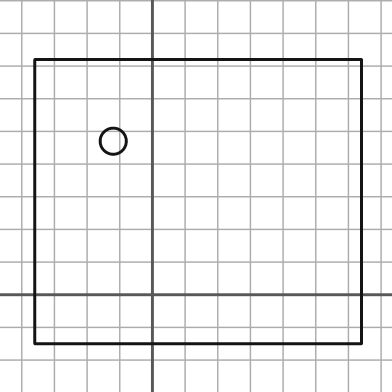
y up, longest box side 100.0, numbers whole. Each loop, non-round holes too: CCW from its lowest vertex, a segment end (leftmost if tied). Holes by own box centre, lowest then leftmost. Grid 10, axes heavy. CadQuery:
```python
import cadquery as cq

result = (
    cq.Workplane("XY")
    .moveTo(-36.0, -15.0)
    .lineTo(64.0, -15.0)
    .lineTo(64.0, 72.0)
    .lineTo(-36.0, 72.0)
    .close()
    .moveTo(-12.0, 47.0)
    .circle(4.0)
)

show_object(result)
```